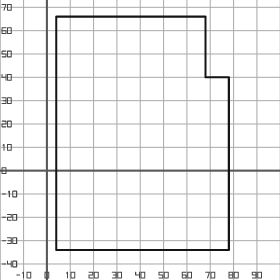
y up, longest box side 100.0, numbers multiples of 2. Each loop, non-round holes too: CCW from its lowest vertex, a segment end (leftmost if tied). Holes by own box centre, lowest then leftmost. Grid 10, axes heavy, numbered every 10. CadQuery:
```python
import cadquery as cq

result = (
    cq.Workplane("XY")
    .moveTo(4.0, -34.0)
    .lineTo(78.0, -34.0)
    .lineTo(78.0, 40.0)
    .lineTo(68.0, 40.0)
    .lineTo(68.0, 66.0)
    .lineTo(4.0, 66.0)
    .close()
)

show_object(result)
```